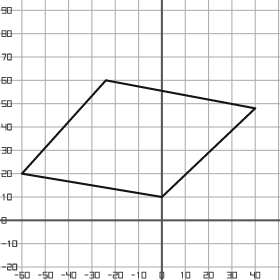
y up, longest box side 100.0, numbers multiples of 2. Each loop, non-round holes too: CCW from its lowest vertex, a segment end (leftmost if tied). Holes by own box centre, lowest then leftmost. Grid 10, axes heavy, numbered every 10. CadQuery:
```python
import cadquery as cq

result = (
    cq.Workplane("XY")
    .moveTo(0.0, 10.0)
    .lineTo(40.0, 48.0)
    .lineTo(-24.0, 60.0)
    .lineTo(-60.0, 20.0)
    .close()
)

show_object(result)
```